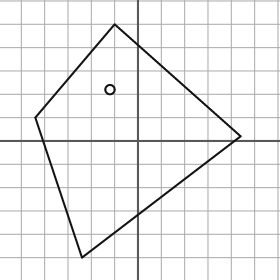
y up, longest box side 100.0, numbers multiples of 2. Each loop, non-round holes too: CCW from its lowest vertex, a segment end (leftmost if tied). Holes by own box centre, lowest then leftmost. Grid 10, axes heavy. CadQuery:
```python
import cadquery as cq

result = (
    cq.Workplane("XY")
    .moveTo(-24.0, -50.0)
    .lineTo(44.0, 2.0)
    .lineTo(-10.0, 50.0)
    .lineTo(-44.0, 10.0)
    .close()
    .moveTo(-12.0, 22.0)
    .circle(2.0)
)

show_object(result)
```